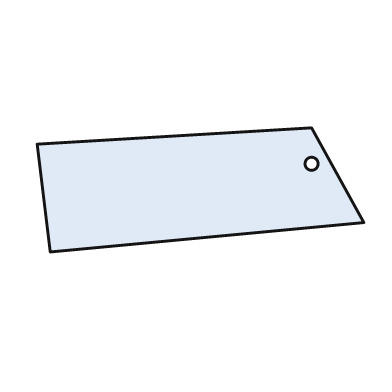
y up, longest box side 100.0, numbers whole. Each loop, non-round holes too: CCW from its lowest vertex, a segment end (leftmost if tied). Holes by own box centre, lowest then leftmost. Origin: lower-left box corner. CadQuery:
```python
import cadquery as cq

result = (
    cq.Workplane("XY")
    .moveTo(4.0, 0.0)
    .lineTo(100.0, 9.0)
    .lineTo(84.0, 38.0)
    .lineTo(0.0, 33.0)
    .close()
    .moveTo(84.0, 27.0)
    .circle(2.0)
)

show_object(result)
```